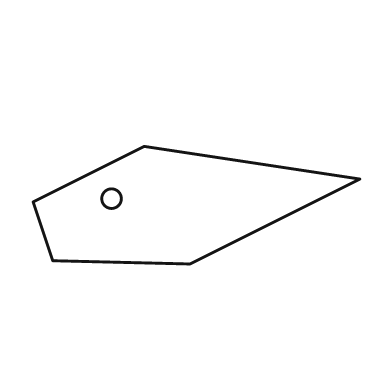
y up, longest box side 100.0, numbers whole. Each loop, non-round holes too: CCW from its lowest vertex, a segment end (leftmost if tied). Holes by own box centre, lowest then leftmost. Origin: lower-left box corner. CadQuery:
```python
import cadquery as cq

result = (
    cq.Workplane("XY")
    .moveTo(48.0, 0.0)
    .lineTo(100.0, 26.0)
    .lineTo(34.0, 36.0)
    .lineTo(0.0, 19.0)
    .lineTo(6.0, 1.0)
    .close()
    .moveTo(24.0, 20.0)
    .circle(3.0)
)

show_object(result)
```